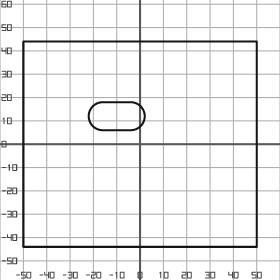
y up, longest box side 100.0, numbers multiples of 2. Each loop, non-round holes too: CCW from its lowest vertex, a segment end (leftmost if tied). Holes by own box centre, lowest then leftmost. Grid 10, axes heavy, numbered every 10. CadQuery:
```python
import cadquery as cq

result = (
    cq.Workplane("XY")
    .moveTo(-50.0, -44.0)
    .lineTo(50.0, -44.0)
    .lineTo(50.0, 44.0)
    .lineTo(-50.0, 44.0)
    .close()
    .moveTo(-16.0, 6.0)
    .lineTo(-4.0, 6.0)
    .threePointArc((2.0, 12.0), (-4.0, 18.0))
    .lineTo(-16.0, 18.0)
    .threePointArc((-22.0, 12.0), (-16.0, 6.0))
    .close()
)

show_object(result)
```